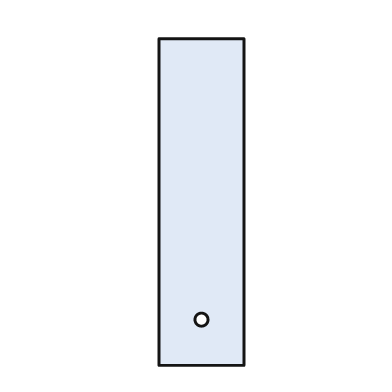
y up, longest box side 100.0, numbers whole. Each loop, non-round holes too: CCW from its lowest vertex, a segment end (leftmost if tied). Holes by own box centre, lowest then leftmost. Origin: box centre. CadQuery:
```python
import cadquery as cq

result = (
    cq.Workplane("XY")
    .moveTo(-13.0, -50.0)
    .lineTo(13.0, -50.0)
    .lineTo(13.0, 50.0)
    .lineTo(-13.0, 50.0)
    .close()
    .moveTo(0.0, -36.0)
    .circle(2.0)
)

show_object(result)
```